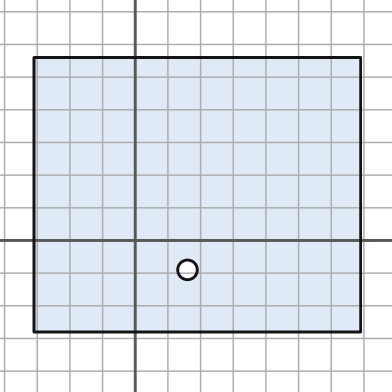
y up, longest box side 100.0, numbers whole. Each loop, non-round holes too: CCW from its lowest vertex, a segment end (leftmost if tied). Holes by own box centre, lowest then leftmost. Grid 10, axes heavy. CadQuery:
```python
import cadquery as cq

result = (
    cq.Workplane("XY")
    .moveTo(-31.0, -28.0)
    .lineTo(69.0, -28.0)
    .lineTo(69.0, 56.0)
    .lineTo(-31.0, 56.0)
    .close()
    .moveTo(16.0, -9.0)
    .circle(3.0)
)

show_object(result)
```